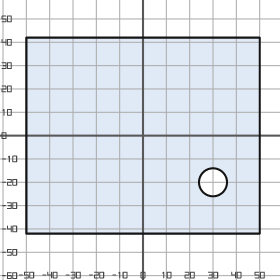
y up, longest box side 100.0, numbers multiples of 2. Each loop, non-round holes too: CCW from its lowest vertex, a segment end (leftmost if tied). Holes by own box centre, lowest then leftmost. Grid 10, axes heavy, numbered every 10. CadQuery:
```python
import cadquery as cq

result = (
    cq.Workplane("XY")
    .moveTo(-50.0, -42.0)
    .lineTo(50.0, -42.0)
    .lineTo(50.0, 42.0)
    .lineTo(-50.0, 42.0)
    .close()
    .moveTo(30.0, -20.0)
    .circle(6.0)
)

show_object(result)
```